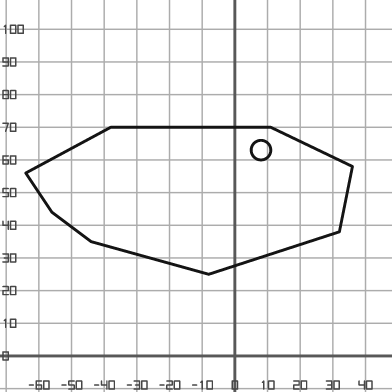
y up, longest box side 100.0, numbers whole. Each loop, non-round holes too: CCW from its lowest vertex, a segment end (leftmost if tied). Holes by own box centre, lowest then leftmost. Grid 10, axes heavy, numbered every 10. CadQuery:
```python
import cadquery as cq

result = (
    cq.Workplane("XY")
    .moveTo(-8.0, 25.0)
    .lineTo(32.0, 38.0)
    .lineTo(36.0, 58.0)
    .lineTo(11.0, 70.0)
    .lineTo(-38.0, 70.0)
    .lineTo(-64.0, 56.0)
    .lineTo(-56.0, 44.0)
    .lineTo(-44.0, 35.0)
    .close()
    .moveTo(8.0, 63.0)
    .circle(3.0)
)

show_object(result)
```